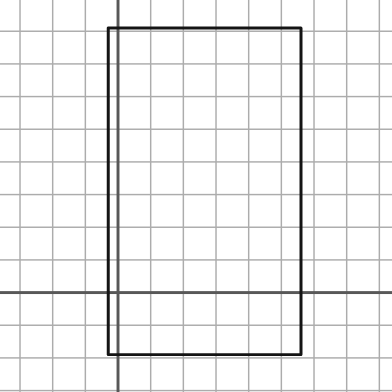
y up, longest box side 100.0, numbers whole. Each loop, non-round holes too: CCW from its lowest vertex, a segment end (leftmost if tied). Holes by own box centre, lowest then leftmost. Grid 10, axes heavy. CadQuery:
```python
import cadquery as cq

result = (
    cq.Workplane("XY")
    .moveTo(-3.0, -19.0)
    .lineTo(56.0, -19.0)
    .lineTo(56.0, 81.0)
    .lineTo(-3.0, 81.0)
    .close()
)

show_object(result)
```